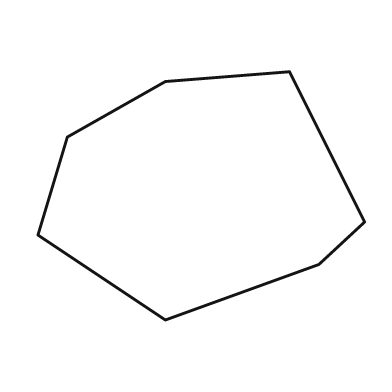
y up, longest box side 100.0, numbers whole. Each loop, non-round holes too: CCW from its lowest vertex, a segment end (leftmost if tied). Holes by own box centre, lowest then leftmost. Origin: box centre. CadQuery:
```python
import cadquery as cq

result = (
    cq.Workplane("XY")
    .moveTo(-11.0, -38.0)
    .lineTo(36.0, -21.0)
    .lineTo(50.0, -8.0)
    .lineTo(27.0, 38.0)
    .lineTo(-11.0, 35.0)
    .lineTo(-41.0, 18.0)
    .lineTo(-50.0, -12.0)
    .close()
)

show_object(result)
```